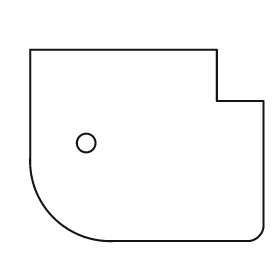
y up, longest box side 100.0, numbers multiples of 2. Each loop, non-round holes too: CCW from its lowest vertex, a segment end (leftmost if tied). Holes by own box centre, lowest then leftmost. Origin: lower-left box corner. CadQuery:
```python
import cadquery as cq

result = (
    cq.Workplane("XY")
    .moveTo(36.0, 0.0)
    .lineTo(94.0, 0.0)
    .threePointArc((98.0, 2.0), (100.0, 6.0))
    .lineTo(100.0, 60.0)
    .lineTo(80.0, 60.0)
    .lineTo(80.0, 82.0)
    .lineTo(0.0, 82.0)
    .lineTo(0.0, 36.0)
    .threePointArc((10.0, 10.0), (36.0, 0.0))
    .close()
    .moveTo(24.0, 42.0)
    .circle(4.0)
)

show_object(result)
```